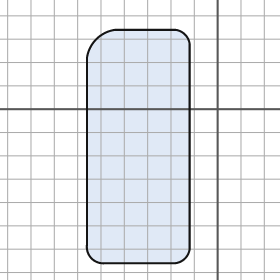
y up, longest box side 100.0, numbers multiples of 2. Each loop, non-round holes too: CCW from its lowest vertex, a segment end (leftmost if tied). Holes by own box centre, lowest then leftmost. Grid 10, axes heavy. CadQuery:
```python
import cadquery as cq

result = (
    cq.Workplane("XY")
    .moveTo(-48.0, -66.0)
    .lineTo(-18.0, -66.0)
    .threePointArc((-14.0, -64.0), (-12.0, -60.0))
    .lineTo(-12.0, 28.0)
    .threePointArc((-14.0, 32.0), (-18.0, 34.0))
    .lineTo(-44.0, 34.0)
    .threePointArc((-52.0, 30.0), (-56.0, 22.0))
    .lineTo(-56.0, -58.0)
    .threePointArc((-54.0, -64.0), (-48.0, -66.0))
    .close()
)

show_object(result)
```